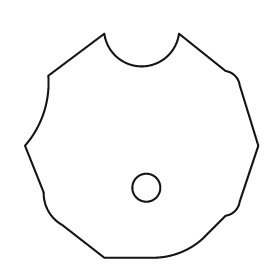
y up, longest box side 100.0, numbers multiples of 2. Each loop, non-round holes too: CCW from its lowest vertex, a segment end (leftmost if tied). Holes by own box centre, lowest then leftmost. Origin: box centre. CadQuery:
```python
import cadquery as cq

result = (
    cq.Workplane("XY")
    .moveTo(-16.0, -48.0)
    .lineTo(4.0, -48.0)
    .threePointArc((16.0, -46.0), (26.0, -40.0))
    .lineTo(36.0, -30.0)
    .threePointArc((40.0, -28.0), (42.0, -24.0))
    .lineTo(50.0, 0.0)
    .lineTo(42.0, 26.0)
    .threePointArc((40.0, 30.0), (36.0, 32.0))
    .lineTo(16.0, 48.0)
    .threePointArc((0.0, 34.0), (-16.0, 48.0))
    .lineTo(-40.0, 30.0)
    .threePointArc((-42.0, 14.0), (-50.0, 0.0))
    .lineTo(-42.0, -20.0)
    .threePointArc((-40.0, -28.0), (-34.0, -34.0))
    .close()
    .moveTo(2.0, -18.0)
    .circle(6.0)
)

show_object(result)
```